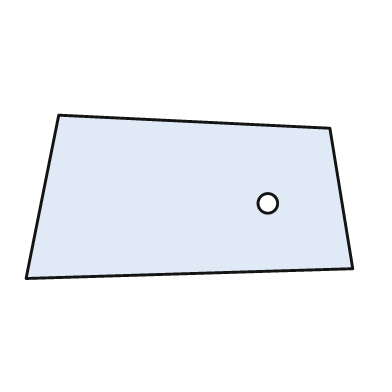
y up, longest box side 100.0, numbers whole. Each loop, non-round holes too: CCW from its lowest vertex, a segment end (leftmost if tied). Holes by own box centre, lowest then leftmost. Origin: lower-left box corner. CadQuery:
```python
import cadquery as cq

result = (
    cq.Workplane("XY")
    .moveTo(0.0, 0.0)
    .lineTo(100.0, 3.0)
    .lineTo(93.0, 46.0)
    .lineTo(10.0, 50.0)
    .close()
    .moveTo(74.0, 23.0)
    .circle(3.0)
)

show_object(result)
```